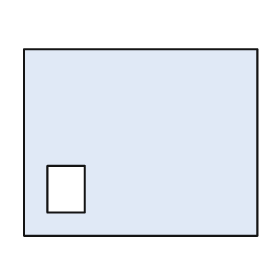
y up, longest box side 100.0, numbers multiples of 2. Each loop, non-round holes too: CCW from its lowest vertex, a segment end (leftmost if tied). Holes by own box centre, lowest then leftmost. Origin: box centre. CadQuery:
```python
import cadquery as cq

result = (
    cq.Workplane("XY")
    .moveTo(-50.0, -40.0)
    .lineTo(50.0, -40.0)
    .lineTo(50.0, 40.0)
    .lineTo(-50.0, 40.0)
    .close()
    .moveTo(-40.0, -30.0)
    .lineTo(-24.0, -30.0)
    .lineTo(-24.0, -10.0)
    .lineTo(-40.0, -10.0)
    .close()
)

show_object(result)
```